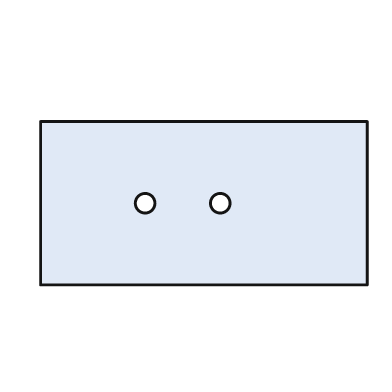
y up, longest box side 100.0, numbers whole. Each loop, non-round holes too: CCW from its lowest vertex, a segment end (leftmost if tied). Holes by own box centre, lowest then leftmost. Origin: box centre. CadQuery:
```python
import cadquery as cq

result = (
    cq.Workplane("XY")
    .moveTo(-50.0, -25.0)
    .lineTo(50.0, -25.0)
    .lineTo(50.0, 25.0)
    .lineTo(-50.0, 25.0)
    .close()
    .moveTo(-18.0, 0.0)
    .circle(3.0)
    .moveTo(5.0, 0.0)
    .circle(3.0)
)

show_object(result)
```